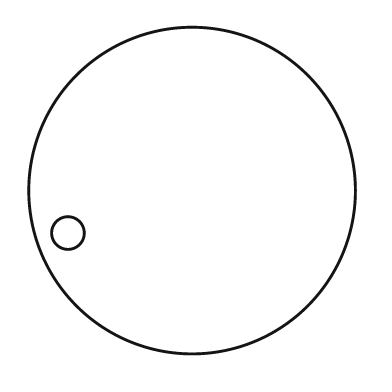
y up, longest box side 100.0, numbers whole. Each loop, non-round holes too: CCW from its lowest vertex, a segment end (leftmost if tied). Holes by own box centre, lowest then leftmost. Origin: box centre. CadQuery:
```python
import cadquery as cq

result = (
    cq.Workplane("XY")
    .moveTo(0.0, 0.0)
    .circle(50.0)
    .moveTo(-38.0, -13.0)
    .circle(5.0)
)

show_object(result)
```